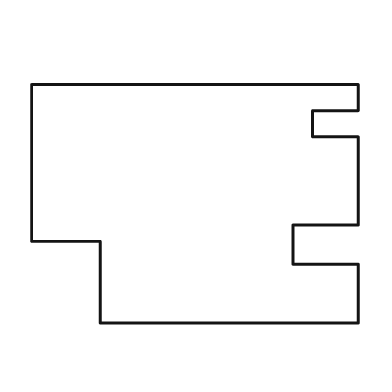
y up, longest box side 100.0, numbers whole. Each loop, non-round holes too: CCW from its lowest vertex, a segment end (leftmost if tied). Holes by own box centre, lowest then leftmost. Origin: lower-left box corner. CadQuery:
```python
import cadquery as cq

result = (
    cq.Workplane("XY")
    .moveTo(21.0, 0.0)
    .lineTo(100.0, 0.0)
    .lineTo(100.0, 18.0)
    .lineTo(80.0, 18.0)
    .lineTo(80.0, 30.0)
    .lineTo(100.0, 30.0)
    .lineTo(100.0, 57.0)
    .lineTo(86.0, 57.0)
    .lineTo(86.0, 65.0)
    .lineTo(100.0, 65.0)
    .lineTo(100.0, 73.0)
    .lineTo(0.0, 73.0)
    .lineTo(0.0, 25.0)
    .lineTo(21.0, 25.0)
    .close()
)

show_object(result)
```